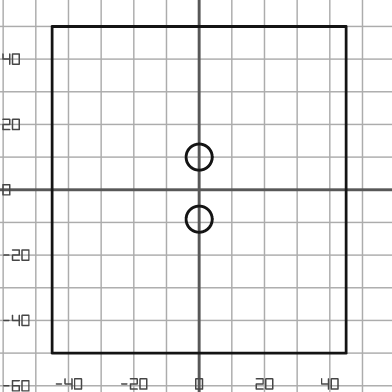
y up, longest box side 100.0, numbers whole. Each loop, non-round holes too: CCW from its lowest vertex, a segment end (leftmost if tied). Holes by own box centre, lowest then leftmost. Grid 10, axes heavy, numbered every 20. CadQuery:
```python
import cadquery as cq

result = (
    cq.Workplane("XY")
    .moveTo(-45.0, -50.0)
    .lineTo(45.0, -50.0)
    .lineTo(45.0, 50.0)
    .lineTo(-45.0, 50.0)
    .close()
    .moveTo(0.0, -9.0)
    .circle(4.0)
    .moveTo(0.0, 10.0)
    .circle(4.0)
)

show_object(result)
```